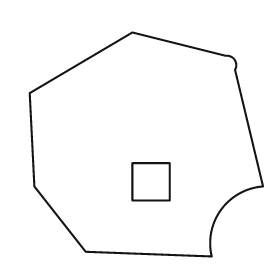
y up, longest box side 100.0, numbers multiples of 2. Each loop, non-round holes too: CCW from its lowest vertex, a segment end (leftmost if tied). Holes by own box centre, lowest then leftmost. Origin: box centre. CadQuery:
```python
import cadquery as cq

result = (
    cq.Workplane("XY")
    .moveTo(28.0, -48.0)
    .threePointArc((32.0, -28.0), (50.0, -18.0))
    .lineTo(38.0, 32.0)
    .threePointArc((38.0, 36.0), (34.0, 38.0))
    .lineTo(-6.0, 48.0)
    .lineTo(-50.0, 22.0)
    .lineTo(-48.0, -18.0)
    .lineTo(-26.0, -46.0)
    .close()
    .moveTo(-6.0, -24.0)
    .lineTo(10.0, -24.0)
    .lineTo(10.0, -8.0)
    .lineTo(-6.0, -8.0)
    .close()
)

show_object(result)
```